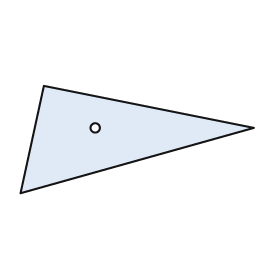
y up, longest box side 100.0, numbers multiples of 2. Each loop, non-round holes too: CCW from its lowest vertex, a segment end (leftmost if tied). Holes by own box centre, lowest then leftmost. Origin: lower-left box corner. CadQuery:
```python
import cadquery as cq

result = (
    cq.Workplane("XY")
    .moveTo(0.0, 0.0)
    .lineTo(100.0, 28.0)
    .lineTo(10.0, 46.0)
    .close()
    .moveTo(32.0, 28.0)
    .circle(2.0)
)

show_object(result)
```